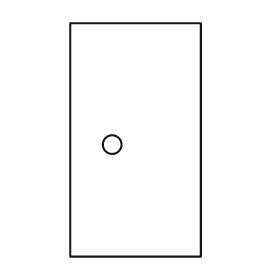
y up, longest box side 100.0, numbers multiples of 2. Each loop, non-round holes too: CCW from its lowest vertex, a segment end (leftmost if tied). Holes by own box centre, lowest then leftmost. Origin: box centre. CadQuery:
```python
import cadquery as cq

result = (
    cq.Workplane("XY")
    .moveTo(-28.0, -50.0)
    .lineTo(28.0, -50.0)
    .lineTo(28.0, 50.0)
    .lineTo(-28.0, 50.0)
    .close()
    .moveTo(-10.0, -2.0)
    .circle(4.0)
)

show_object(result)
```